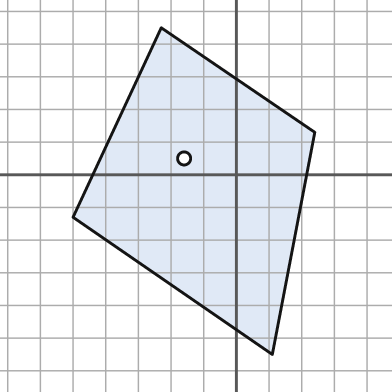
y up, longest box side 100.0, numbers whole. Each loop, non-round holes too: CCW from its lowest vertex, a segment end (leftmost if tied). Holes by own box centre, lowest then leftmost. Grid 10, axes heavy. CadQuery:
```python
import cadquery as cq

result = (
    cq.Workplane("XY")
    .moveTo(11.0, -55.0)
    .lineTo(24.0, 13.0)
    .lineTo(-23.0, 45.0)
    .lineTo(-50.0, -13.0)
    .close()
    .moveTo(-16.0, 5.0)
    .circle(2.0)
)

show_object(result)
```